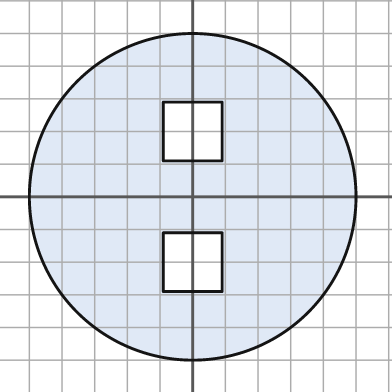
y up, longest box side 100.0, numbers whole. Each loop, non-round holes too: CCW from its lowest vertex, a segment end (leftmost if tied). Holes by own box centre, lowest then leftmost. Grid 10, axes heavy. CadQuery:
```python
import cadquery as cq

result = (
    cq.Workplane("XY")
    .moveTo(0.0, 0.0)
    .circle(50.0)
    .moveTo(-9.0, -29.0)
    .lineTo(9.0, -29.0)
    .lineTo(9.0, -11.0)
    .lineTo(-9.0, -11.0)
    .close()
    .moveTo(-9.0, 11.0)
    .lineTo(9.0, 11.0)
    .lineTo(9.0, 29.0)
    .lineTo(-9.0, 29.0)
    .close()
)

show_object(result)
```